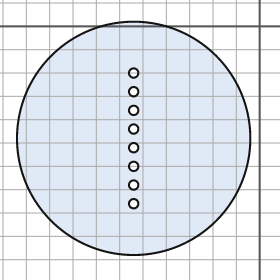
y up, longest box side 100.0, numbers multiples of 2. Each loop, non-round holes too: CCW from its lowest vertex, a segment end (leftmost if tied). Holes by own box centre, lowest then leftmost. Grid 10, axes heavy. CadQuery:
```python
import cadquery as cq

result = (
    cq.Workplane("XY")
    .moveTo(-54.0, -48.0)
    .circle(50.0)
    .moveTo(-54.0, -76.0)
    .circle(2.0)
    .moveTo(-54.0, -68.0)
    .circle(2.0)
    .moveTo(-54.0, -60.0)
    .circle(2.0)
    .moveTo(-54.0, -52.0)
    .circle(2.0)
    .moveTo(-54.0, -44.0)
    .circle(2.0)
    .moveTo(-54.0, -36.0)
    .circle(2.0)
    .moveTo(-54.0, -28.0)
    .circle(2.0)
    .moveTo(-54.0, -20.0)
    .circle(2.0)
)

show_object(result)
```